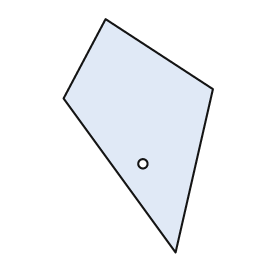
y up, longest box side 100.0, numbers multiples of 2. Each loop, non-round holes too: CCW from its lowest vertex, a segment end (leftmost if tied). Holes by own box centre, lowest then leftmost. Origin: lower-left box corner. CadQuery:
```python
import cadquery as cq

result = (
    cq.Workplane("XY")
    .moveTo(48.0, 0.0)
    .lineTo(64.0, 70.0)
    .lineTo(18.0, 100.0)
    .lineTo(0.0, 66.0)
    .close()
    .moveTo(34.0, 38.0)
    .circle(2.0)
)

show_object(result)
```